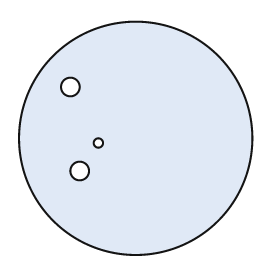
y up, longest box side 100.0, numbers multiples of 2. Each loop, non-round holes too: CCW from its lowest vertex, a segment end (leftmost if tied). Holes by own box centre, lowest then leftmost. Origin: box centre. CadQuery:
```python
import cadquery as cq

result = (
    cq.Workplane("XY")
    .moveTo(0.0, 0.0)
    .circle(50.0)
    .moveTo(-24.0, -14.0)
    .circle(4.0)
    .moveTo(-16.0, -2.0)
    .circle(2.0)
    .moveTo(-28.0, 22.0)
    .circle(4.0)
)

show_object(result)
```